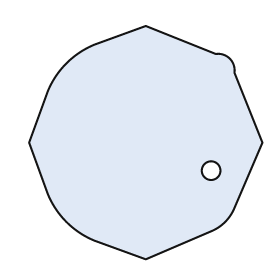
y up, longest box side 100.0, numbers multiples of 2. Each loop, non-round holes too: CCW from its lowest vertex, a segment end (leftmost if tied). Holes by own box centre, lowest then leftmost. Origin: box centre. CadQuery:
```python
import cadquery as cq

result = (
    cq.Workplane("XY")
    .moveTo(0.0, -50.0)
    .lineTo(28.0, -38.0)
    .threePointArc((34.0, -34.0), (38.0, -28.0))
    .lineTo(50.0, 0.0)
    .lineTo(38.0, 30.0)
    .threePointArc((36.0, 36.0), (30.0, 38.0))
    .lineTo(0.0, 50.0)
    .lineTo(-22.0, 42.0)
    .threePointArc((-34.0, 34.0), (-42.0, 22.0))
    .lineTo(-50.0, 0.0)
    .lineTo(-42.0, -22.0)
    .threePointArc((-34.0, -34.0), (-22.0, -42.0))
    .close()
    .moveTo(28.0, -12.0)
    .circle(4.0)
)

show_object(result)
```